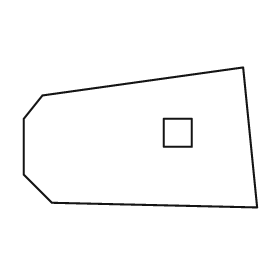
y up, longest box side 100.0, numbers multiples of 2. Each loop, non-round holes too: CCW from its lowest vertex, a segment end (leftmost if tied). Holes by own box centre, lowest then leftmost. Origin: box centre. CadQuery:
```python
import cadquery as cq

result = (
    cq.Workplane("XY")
    .moveTo(50.0, -30.0)
    .lineTo(44.0, 30.0)
    .lineTo(-42.0, 18.0)
    .lineTo(-50.0, 8.0)
    .lineTo(-50.0, -16.0)
    .lineTo(-38.0, -28.0)
    .close()
    .moveTo(10.0, -4.0)
    .lineTo(22.0, -4.0)
    .lineTo(22.0, 8.0)
    .lineTo(10.0, 8.0)
    .close()
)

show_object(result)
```